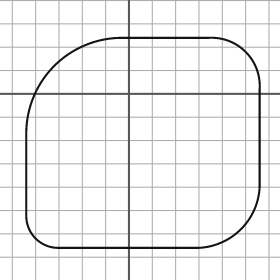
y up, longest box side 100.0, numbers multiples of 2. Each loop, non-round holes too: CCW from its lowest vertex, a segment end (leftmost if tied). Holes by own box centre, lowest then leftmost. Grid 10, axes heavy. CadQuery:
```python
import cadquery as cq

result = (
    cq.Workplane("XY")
    .moveTo(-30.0, -66.0)
    .lineTo(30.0, -66.0)
    .threePointArc((48.0, -58.0), (56.0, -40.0))
    .lineTo(56.0, 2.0)
    .threePointArc((50.0, 18.0), (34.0, 24.0))
    .lineTo(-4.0, 24.0)
    .threePointArc((-32.0, 12.0), (-44.0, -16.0))
    .lineTo(-44.0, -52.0)
    .threePointArc((-40.0, -62.0), (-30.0, -66.0))
    .close()
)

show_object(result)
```